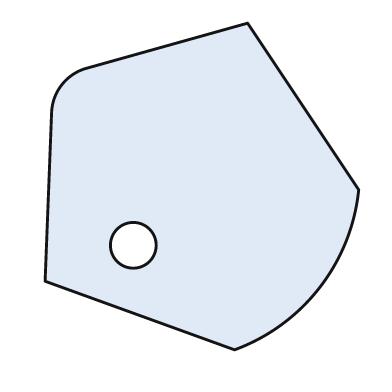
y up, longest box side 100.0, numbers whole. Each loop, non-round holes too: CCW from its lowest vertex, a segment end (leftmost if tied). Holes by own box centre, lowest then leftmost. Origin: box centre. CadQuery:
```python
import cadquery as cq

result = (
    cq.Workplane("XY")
    .moveTo(10.0, -50.0)
    .threePointArc((36.0, -31.0), (48.0, -1.0))
    .lineTo(14.0, 50.0)
    .lineTo(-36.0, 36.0)
    .threePointArc((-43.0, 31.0), (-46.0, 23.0))
    .lineTo(-48.0, -29.0)
    .close()
    .moveTo(-21.0, -18.0)
    .circle(7.0)
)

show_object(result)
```